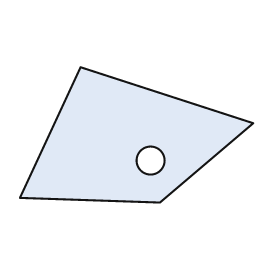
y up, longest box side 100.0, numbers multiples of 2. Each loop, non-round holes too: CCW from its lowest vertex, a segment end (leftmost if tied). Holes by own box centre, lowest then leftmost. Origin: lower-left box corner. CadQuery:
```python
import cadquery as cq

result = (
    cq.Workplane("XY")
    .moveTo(60.0, 0.0)
    .lineTo(100.0, 34.0)
    .lineTo(26.0, 58.0)
    .lineTo(0.0, 2.0)
    .close()
    .moveTo(56.0, 18.0)
    .circle(6.0)
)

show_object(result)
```